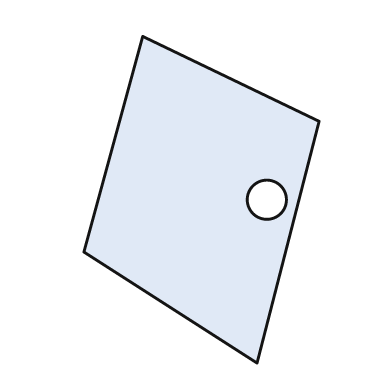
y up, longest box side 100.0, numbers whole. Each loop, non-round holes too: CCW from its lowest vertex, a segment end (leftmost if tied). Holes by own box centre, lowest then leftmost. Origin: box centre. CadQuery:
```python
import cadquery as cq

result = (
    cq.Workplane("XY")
    .moveTo(17.0, -50.0)
    .lineTo(36.0, 24.0)
    .lineTo(-18.0, 50.0)
    .lineTo(-36.0, -16.0)
    .close()
    .moveTo(20.0, 0.0)
    .circle(6.0)
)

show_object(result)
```